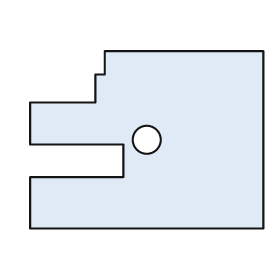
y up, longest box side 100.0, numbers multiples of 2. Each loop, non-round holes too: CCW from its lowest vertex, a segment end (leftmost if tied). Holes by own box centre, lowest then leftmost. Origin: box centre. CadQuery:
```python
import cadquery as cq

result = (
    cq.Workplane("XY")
    .moveTo(-50.0, -38.0)
    .lineTo(50.0, -38.0)
    .lineTo(50.0, 38.0)
    .lineTo(-18.0, 38.0)
    .lineTo(-18.0, 28.0)
    .lineTo(-22.0, 28.0)
    .lineTo(-22.0, 16.0)
    .lineTo(-50.0, 16.0)
    .lineTo(-50.0, -2.0)
    .lineTo(-10.0, -2.0)
    .lineTo(-10.0, -16.0)
    .lineTo(-50.0, -16.0)
    .close()
    .moveTo(0.0, 0.0)
    .circle(6.0)
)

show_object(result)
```